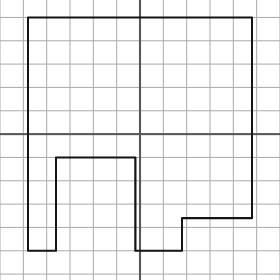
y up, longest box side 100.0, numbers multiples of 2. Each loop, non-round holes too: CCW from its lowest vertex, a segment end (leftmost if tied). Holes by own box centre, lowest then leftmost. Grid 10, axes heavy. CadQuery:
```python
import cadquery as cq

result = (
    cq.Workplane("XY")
    .moveTo(-48.0, -50.0)
    .lineTo(-36.0, -50.0)
    .lineTo(-36.0, -10.0)
    .lineTo(-2.0, -10.0)
    .lineTo(-2.0, -50.0)
    .lineTo(18.0, -50.0)
    .lineTo(18.0, -36.0)
    .lineTo(48.0, -36.0)
    .lineTo(48.0, 50.0)
    .lineTo(-48.0, 50.0)
    .close()
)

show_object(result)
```